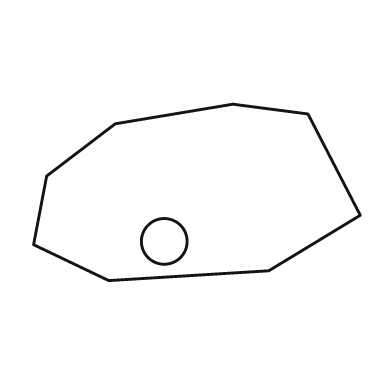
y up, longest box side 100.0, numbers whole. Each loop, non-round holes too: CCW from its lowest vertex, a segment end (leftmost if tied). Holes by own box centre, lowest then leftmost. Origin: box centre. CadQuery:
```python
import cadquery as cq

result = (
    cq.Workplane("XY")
    .moveTo(-27.0, -27.0)
    .lineTo(22.0, -24.0)
    .lineTo(50.0, -7.0)
    .lineTo(34.0, 24.0)
    .lineTo(11.0, 27.0)
    .lineTo(-25.0, 21.0)
    .lineTo(-46.0, 5.0)
    .lineTo(-50.0, -16.0)
    .close()
    .moveTo(-10.0, -15.0)
    .circle(7.0)
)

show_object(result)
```